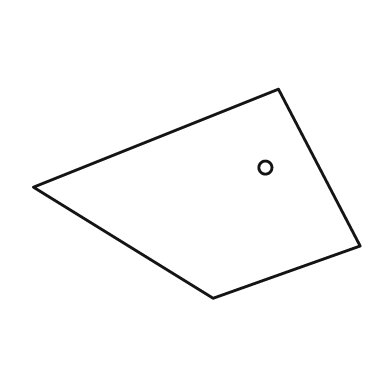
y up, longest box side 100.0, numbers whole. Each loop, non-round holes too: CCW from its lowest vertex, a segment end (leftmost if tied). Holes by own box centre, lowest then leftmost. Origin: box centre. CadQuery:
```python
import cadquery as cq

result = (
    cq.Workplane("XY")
    .moveTo(5.0, -32.0)
    .lineTo(50.0, -16.0)
    .lineTo(25.0, 32.0)
    .lineTo(-50.0, 2.0)
    .close()
    .moveTo(21.0, 8.0)
    .circle(2.0)
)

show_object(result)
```